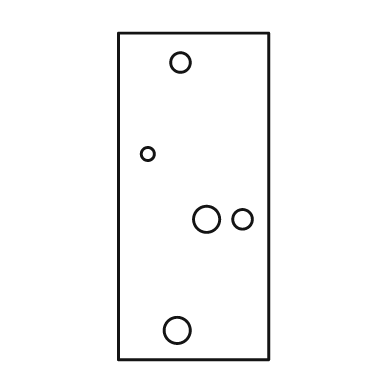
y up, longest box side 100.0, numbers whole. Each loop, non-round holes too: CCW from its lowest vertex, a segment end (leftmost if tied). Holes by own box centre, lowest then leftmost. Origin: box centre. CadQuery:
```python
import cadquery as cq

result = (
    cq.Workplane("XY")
    .moveTo(-23.0, -50.0)
    .lineTo(23.0, -50.0)
    .lineTo(23.0, 50.0)
    .lineTo(-23.0, 50.0)
    .close()
    .moveTo(-5.0, -41.0)
    .circle(4.0)
    .moveTo(4.0, -7.0)
    .circle(4.0)
    .moveTo(15.0, -7.0)
    .circle(3.0)
    .moveTo(-14.0, 13.0)
    .circle(2.0)
    .moveTo(-4.0, 41.0)
    .circle(3.0)
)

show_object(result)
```